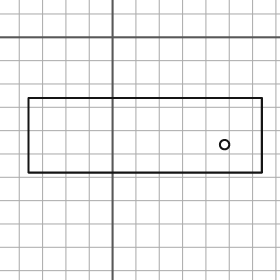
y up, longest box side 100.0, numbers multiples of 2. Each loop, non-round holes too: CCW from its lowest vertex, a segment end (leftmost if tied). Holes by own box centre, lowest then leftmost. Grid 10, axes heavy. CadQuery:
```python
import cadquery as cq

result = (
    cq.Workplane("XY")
    .moveTo(-36.0, -58.0)
    .lineTo(64.0, -58.0)
    .lineTo(64.0, -26.0)
    .lineTo(-36.0, -26.0)
    .close()
    .moveTo(48.0, -46.0)
    .circle(2.0)
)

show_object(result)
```